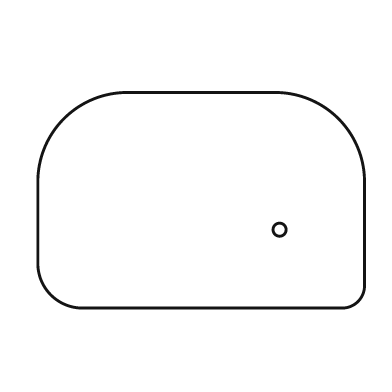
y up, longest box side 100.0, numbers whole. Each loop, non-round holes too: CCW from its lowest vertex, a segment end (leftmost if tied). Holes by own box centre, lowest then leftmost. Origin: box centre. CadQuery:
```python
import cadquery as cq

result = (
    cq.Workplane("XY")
    .moveTo(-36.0, -33.0)
    .lineTo(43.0, -33.0)
    .threePointArc((48.0, -31.0), (50.0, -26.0))
    .lineTo(50.0, 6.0)
    .threePointArc((42.0, 25.0), (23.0, 33.0))
    .lineTo(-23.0, 33.0)
    .threePointArc((-42.0, 25.0), (-50.0, 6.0))
    .lineTo(-50.0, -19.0)
    .threePointArc((-46.0, -29.0), (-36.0, -33.0))
    .close()
    .moveTo(24.0, -9.0)
    .circle(2.0)
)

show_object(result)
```